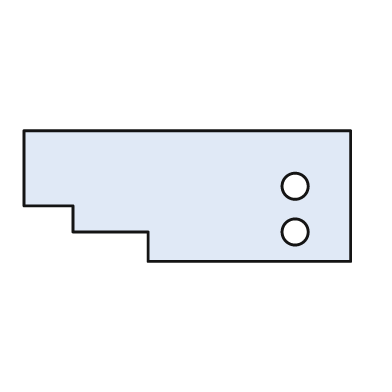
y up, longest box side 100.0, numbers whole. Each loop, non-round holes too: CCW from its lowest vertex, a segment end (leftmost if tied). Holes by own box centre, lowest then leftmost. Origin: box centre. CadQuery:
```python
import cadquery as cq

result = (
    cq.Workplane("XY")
    .moveTo(-12.0, -20.0)
    .lineTo(50.0, -20.0)
    .lineTo(50.0, 20.0)
    .lineTo(-50.0, 20.0)
    .lineTo(-50.0, -3.0)
    .lineTo(-35.0, -3.0)
    .lineTo(-35.0, -11.0)
    .lineTo(-12.0, -11.0)
    .close()
    .moveTo(33.0, -11.0)
    .circle(4.0)
    .moveTo(33.0, 3.0)
    .circle(4.0)
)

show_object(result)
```